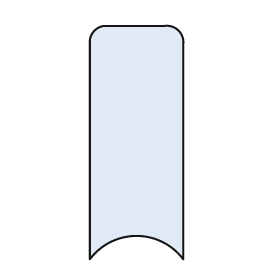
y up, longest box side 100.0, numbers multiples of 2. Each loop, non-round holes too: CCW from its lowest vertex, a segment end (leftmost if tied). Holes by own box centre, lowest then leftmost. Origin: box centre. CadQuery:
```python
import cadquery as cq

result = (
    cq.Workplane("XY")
    .moveTo(-20.0, -50.0)
    .threePointArc((0.0, -40.0), (20.0, -50.0))
    .lineTo(20.0, 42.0)
    .threePointArc((18.0, 48.0), (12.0, 50.0))
    .lineTo(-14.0, 50.0)
    .threePointArc((-18.0, 48.0), (-20.0, 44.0))
    .close()
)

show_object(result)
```